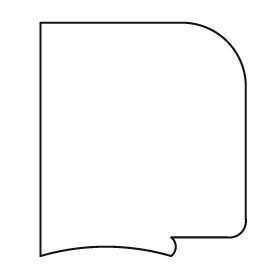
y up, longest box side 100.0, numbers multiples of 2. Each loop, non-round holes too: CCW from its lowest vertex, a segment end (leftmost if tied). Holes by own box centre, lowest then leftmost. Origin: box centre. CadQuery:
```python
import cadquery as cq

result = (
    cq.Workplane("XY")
    .moveTo(-44.0, -50.0)
    .threePointArc((-16.0, -46.0), (12.0, -50.0))
    .threePointArc((14.0, -46.0), (12.0, -42.0))
    .lineTo(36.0, -42.0)
    .threePointArc((42.0, -40.0), (44.0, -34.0))
    .lineTo(44.0, 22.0)
    .threePointArc((36.0, 42.0), (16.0, 50.0))
    .lineTo(-44.0, 50.0)
    .close()
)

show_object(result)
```